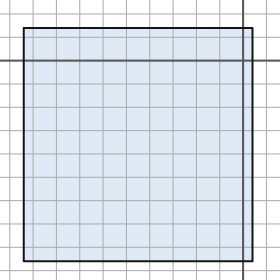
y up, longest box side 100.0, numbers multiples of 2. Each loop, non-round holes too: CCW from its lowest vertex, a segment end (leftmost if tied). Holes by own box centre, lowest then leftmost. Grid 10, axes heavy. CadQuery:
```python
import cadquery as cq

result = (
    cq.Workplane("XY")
    .moveTo(-94.0, -86.0)
    .lineTo(4.0, -86.0)
    .lineTo(4.0, 14.0)
    .lineTo(-94.0, 14.0)
    .close()
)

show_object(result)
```